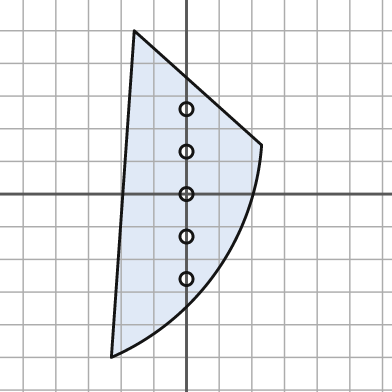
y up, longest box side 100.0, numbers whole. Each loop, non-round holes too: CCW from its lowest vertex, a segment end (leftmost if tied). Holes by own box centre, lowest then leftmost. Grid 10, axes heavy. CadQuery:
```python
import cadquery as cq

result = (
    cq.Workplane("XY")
    .moveTo(-23.0, -50.0)
    .threePointArc((9.0, -24.0), (23.0, 15.0))
    .lineTo(-16.0, 50.0)
    .close()
    .moveTo(0.0, -26.0)
    .circle(2.0)
    .moveTo(0.0, -13.0)
    .circle(2.0)
    .moveTo(0.0, 0.0)
    .circle(2.0)
    .moveTo(0.0, 13.0)
    .circle(2.0)
    .moveTo(0.0, 26.0)
    .circle(2.0)
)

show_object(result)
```